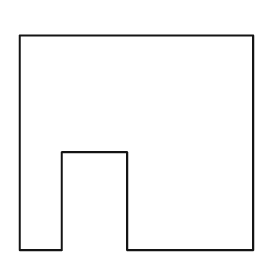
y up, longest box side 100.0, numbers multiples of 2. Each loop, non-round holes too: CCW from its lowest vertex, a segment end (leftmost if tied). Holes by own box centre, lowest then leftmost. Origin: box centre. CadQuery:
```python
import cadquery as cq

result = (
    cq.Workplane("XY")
    .moveTo(-50.0, -46.0)
    .lineTo(-32.0, -46.0)
    .lineTo(-32.0, -4.0)
    .lineTo(-4.0, -4.0)
    .lineTo(-4.0, -46.0)
    .lineTo(50.0, -46.0)
    .lineTo(50.0, 46.0)
    .lineTo(-50.0, 46.0)
    .close()
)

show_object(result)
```